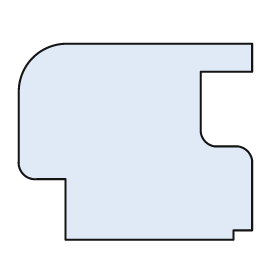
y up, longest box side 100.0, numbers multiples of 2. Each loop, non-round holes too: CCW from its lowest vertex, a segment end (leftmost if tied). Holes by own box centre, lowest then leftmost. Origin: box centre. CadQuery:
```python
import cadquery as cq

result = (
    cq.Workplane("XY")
    .moveTo(-30.0, -42.0)
    .lineTo(42.0, -42.0)
    .lineTo(42.0, -38.0)
    .lineTo(50.0, -38.0)
    .lineTo(50.0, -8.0)
    .threePointArc((48.0, -4.0), (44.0, -2.0))
    .lineTo(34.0, -2.0)
    .threePointArc((30.0, 0.0), (28.0, 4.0))
    .lineTo(28.0, 30.0)
    .lineTo(50.0, 30.0)
    .lineTo(50.0, 42.0)
    .lineTo(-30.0, 42.0)
    .threePointArc((-44.0, 36.0), (-50.0, 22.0))
    .lineTo(-50.0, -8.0)
    .threePointArc((-48.0, -14.0), (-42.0, -16.0))
    .lineTo(-30.0, -16.0)
    .close()
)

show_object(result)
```